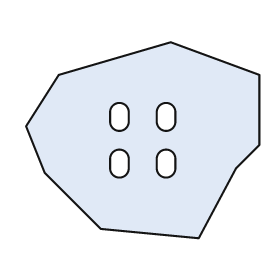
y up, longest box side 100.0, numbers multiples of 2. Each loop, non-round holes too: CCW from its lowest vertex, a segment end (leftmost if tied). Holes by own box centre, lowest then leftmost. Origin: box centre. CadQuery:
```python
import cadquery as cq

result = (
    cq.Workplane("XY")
    .moveTo(24.0, -42.0)
    .lineTo(40.0, -12.0)
    .lineTo(50.0, -2.0)
    .lineTo(50.0, 28.0)
    .lineTo(12.0, 42.0)
    .lineTo(-36.0, 28.0)
    .lineTo(-50.0, 6.0)
    .lineTo(-42.0, -14.0)
    .lineTo(-18.0, -38.0)
    .close()
    .moveTo(-14.0, -12.0)
    .threePointArc((-10.0, -16.0), (-6.0, -12.0))
    .lineTo(-6.0, -8.0)
    .threePointArc((-10.0, -4.0), (-14.0, -8.0))
    .close()
    .moveTo(6.0, -12.0)
    .threePointArc((10.0, -16.0), (14.0, -12.0))
    .lineTo(14.0, -8.0)
    .threePointArc((10.0, -4.0), (6.0, -8.0))
    .close()
    .moveTo(-14.0, 8.0)
    .threePointArc((-10.0, 4.0), (-6.0, 8.0))
    .lineTo(-6.0, 12.0)
    .threePointArc((-10.0, 16.0), (-14.0, 12.0))
    .close()
    .moveTo(6.0, 8.0)
    .threePointArc((10.0, 4.0), (14.0, 8.0))
    .lineTo(14.0, 12.0)
    .threePointArc((10.0, 16.0), (6.0, 12.0))
    .close()
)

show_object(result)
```